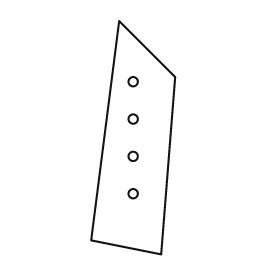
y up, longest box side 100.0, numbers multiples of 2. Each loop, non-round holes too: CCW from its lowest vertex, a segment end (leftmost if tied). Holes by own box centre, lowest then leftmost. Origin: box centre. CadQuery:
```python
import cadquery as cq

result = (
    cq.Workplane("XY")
    .moveTo(12.0, -50.0)
    .lineTo(18.0, 26.0)
    .lineTo(-6.0, 50.0)
    .lineTo(-18.0, -44.0)
    .close()
    .moveTo(0.0, -24.0)
    .circle(2.0)
    .moveTo(0.0, -8.0)
    .circle(2.0)
    .moveTo(0.0, 8.0)
    .circle(2.0)
    .moveTo(0.0, 24.0)
    .circle(2.0)
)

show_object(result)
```